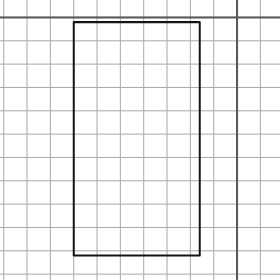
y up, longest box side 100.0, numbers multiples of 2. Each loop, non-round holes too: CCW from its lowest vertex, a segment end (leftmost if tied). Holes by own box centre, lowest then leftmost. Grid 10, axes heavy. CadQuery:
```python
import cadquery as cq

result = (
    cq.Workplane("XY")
    .moveTo(-70.0, -102.0)
    .lineTo(-16.0, -102.0)
    .lineTo(-16.0, -2.0)
    .lineTo(-70.0, -2.0)
    .close()
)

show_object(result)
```